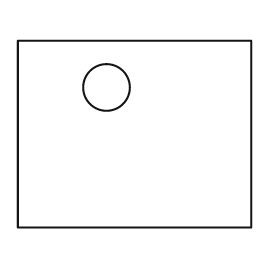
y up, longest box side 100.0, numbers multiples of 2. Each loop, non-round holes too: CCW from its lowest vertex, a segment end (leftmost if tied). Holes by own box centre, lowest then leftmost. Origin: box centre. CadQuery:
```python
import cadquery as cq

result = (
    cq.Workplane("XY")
    .moveTo(-50.0, -40.0)
    .lineTo(50.0, -40.0)
    .lineTo(50.0, 40.0)
    .lineTo(-50.0, 40.0)
    .close()
    .moveTo(-12.0, 20.0)
    .circle(10.0)
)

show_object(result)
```